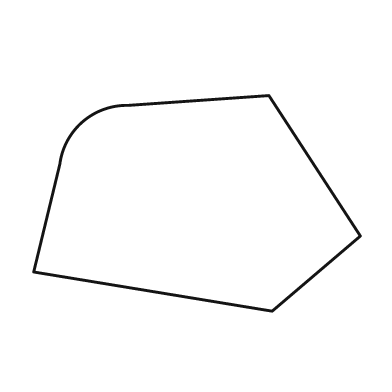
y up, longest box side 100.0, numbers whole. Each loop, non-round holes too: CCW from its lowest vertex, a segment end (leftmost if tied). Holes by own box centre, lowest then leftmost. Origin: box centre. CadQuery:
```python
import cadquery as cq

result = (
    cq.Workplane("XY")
    .moveTo(23.0, -33.0)
    .lineTo(50.0, -10.0)
    .lineTo(22.0, 33.0)
    .lineTo(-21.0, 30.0)
    .threePointArc((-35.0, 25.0), (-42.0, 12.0))
    .lineTo(-50.0, -21.0)
    .close()
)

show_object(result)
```